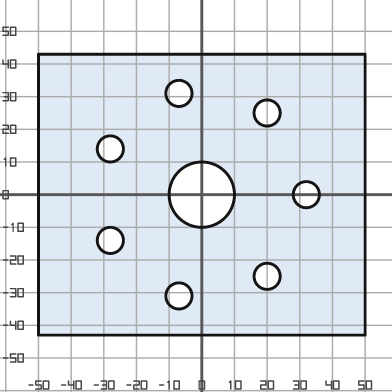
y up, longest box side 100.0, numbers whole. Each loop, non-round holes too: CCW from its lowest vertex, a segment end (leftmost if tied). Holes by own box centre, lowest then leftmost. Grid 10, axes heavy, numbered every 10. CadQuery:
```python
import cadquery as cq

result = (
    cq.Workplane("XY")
    .moveTo(-50.0, -43.0)
    .lineTo(50.0, -43.0)
    .lineTo(50.0, 43.0)
    .lineTo(-50.0, 43.0)
    .close()
    .moveTo(-7.0, -31.0)
    .circle(4.0)
    .moveTo(20.0, -25.0)
    .circle(4.0)
    .moveTo(-28.0, -14.0)
    .circle(4.0)
    .moveTo(0.0, 0.0)
    .circle(10.0)
    .moveTo(32.0, 0.0)
    .circle(4.0)
    .moveTo(-28.0, 14.0)
    .circle(4.0)
    .moveTo(20.0, 25.0)
    .circle(4.0)
    .moveTo(-7.0, 31.0)
    .circle(4.0)
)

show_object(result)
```